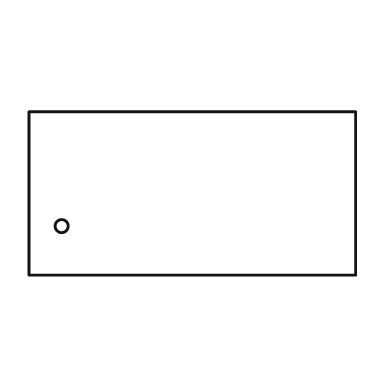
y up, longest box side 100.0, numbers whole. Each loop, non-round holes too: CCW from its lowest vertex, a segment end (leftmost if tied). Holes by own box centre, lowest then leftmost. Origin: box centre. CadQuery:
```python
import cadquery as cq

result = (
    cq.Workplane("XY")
    .moveTo(-50.0, -25.0)
    .lineTo(50.0, -25.0)
    .lineTo(50.0, 25.0)
    .lineTo(-50.0, 25.0)
    .close()
    .moveTo(-40.0, -10.0)
    .circle(2.0)
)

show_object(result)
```